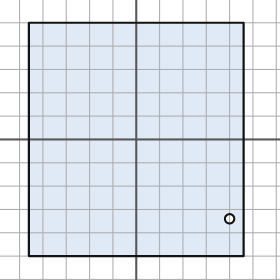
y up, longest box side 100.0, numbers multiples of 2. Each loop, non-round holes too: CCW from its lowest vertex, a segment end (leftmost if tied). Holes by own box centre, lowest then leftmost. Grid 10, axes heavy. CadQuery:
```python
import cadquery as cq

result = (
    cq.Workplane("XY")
    .moveTo(-46.0, -50.0)
    .lineTo(46.0, -50.0)
    .lineTo(46.0, 50.0)
    .lineTo(-46.0, 50.0)
    .close()
    .moveTo(40.0, -34.0)
    .circle(2.0)
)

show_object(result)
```